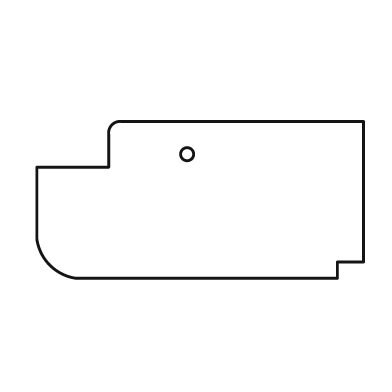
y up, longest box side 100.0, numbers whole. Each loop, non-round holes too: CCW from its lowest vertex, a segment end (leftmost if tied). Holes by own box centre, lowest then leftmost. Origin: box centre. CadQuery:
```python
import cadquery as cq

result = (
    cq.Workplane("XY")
    .moveTo(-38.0, -24.0)
    .lineTo(42.0, -24.0)
    .lineTo(42.0, -19.0)
    .lineTo(50.0, -19.0)
    .lineTo(50.0, 24.0)
    .lineTo(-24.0, 24.0)
    .threePointArc((-27.0, 23.0), (-28.0, 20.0))
    .lineTo(-28.0, 10.0)
    .lineTo(-50.0, 10.0)
    .lineTo(-50.0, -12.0)
    .threePointArc((-46.0, -20.0), (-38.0, -24.0))
    .close()
    .moveTo(-4.0, 14.0)
    .circle(2.0)
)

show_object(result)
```